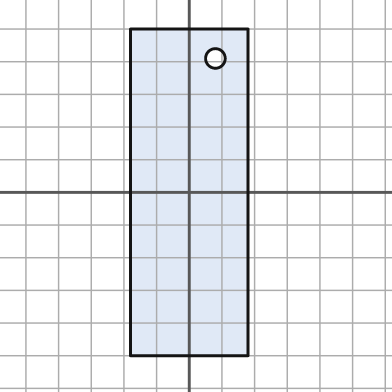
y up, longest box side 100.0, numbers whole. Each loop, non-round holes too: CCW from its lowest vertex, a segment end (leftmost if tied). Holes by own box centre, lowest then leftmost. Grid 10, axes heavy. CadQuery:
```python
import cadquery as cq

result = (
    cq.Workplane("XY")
    .moveTo(-18.0, -50.0)
    .lineTo(18.0, -50.0)
    .lineTo(18.0, 50.0)
    .lineTo(-18.0, 50.0)
    .close()
    .moveTo(8.0, 41.0)
    .circle(3.0)
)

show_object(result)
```